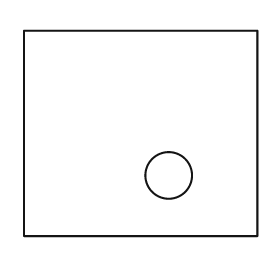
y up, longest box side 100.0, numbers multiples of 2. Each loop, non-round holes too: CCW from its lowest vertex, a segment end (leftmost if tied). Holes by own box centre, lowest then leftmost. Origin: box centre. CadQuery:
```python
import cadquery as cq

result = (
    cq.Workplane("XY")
    .moveTo(-50.0, -44.0)
    .lineTo(50.0, -44.0)
    .lineTo(50.0, 44.0)
    .lineTo(-50.0, 44.0)
    .close()
    .moveTo(12.0, -18.0)
    .circle(10.0)
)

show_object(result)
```